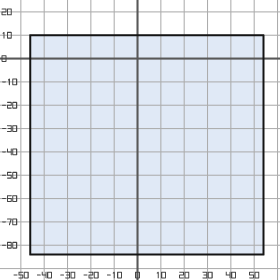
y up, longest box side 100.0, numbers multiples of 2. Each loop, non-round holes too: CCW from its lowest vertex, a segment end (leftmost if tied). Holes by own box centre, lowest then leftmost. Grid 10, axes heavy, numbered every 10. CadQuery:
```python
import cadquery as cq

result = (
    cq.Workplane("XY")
    .moveTo(-46.0, -84.0)
    .lineTo(54.0, -84.0)
    .lineTo(54.0, 10.0)
    .lineTo(-46.0, 10.0)
    .close()
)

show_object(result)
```